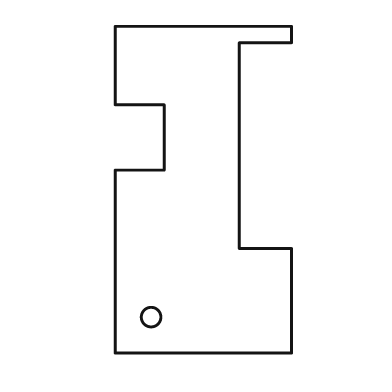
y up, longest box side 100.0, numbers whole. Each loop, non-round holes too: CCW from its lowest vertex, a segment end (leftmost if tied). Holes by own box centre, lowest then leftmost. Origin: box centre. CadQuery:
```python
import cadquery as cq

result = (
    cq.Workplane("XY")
    .moveTo(-27.0, -50.0)
    .lineTo(27.0, -50.0)
    .lineTo(27.0, -18.0)
    .lineTo(11.0, -18.0)
    .lineTo(11.0, 45.0)
    .lineTo(27.0, 45.0)
    .lineTo(27.0, 50.0)
    .lineTo(-27.0, 50.0)
    .lineTo(-27.0, 26.0)
    .lineTo(-12.0, 26.0)
    .lineTo(-12.0, 6.0)
    .lineTo(-27.0, 6.0)
    .close()
    .moveTo(-16.0, -39.0)
    .circle(3.0)
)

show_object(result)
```